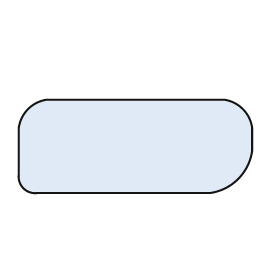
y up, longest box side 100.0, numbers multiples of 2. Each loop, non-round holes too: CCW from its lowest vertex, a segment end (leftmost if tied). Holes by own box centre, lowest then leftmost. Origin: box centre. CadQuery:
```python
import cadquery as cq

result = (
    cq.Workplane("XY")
    .moveTo(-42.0, -20.0)
    .lineTo(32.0, -20.0)
    .threePointArc((44.0, -14.0), (50.0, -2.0))
    .lineTo(50.0, 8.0)
    .threePointArc((46.0, 16.0), (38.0, 20.0))
    .lineTo(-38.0, 20.0)
    .threePointArc((-46.0, 16.0), (-50.0, 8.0))
    .lineTo(-50.0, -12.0)
    .threePointArc((-48.0, -18.0), (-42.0, -20.0))
    .close()
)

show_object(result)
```